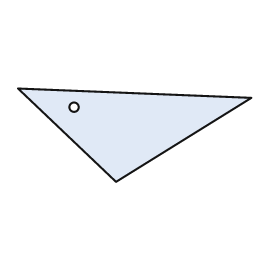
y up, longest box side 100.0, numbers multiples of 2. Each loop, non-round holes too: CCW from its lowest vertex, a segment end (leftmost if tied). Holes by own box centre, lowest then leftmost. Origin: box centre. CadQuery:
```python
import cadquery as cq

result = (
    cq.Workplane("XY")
    .moveTo(-8.0, -20.0)
    .lineTo(50.0, 16.0)
    .lineTo(-50.0, 20.0)
    .close()
    .moveTo(-26.0, 12.0)
    .circle(2.0)
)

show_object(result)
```